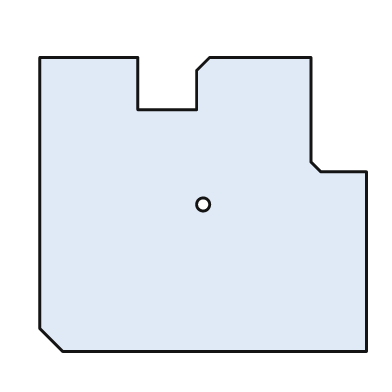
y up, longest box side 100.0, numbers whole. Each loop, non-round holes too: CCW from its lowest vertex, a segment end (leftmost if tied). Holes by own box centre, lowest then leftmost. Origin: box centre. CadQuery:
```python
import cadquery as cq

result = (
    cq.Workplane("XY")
    .moveTo(-43.0, -45.0)
    .lineTo(50.0, -45.0)
    .lineTo(50.0, 10.0)
    .lineTo(36.0, 10.0)
    .lineTo(33.0, 13.0)
    .lineTo(33.0, 45.0)
    .lineTo(2.0, 45.0)
    .lineTo(-2.0, 41.0)
    .lineTo(-2.0, 29.0)
    .lineTo(-20.0, 29.0)
    .lineTo(-20.0, 45.0)
    .lineTo(-50.0, 45.0)
    .lineTo(-50.0, -38.0)
    .close()
    .moveTo(0.0, 0.0)
    .circle(2.0)
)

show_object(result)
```